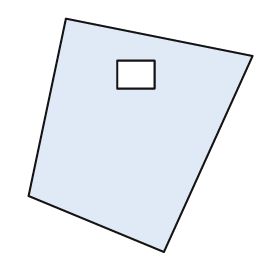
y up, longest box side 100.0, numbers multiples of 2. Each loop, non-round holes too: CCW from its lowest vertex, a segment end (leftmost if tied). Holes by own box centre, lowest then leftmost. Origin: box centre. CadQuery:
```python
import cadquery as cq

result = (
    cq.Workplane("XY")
    .moveTo(10.0, -50.0)
    .lineTo(48.0, 34.0)
    .lineTo(-32.0, 50.0)
    .lineTo(-48.0, -26.0)
    .close()
    .moveTo(-10.0, 20.0)
    .lineTo(6.0, 20.0)
    .lineTo(6.0, 32.0)
    .lineTo(-10.0, 32.0)
    .close()
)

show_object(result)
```